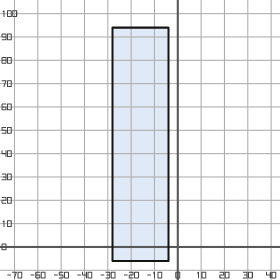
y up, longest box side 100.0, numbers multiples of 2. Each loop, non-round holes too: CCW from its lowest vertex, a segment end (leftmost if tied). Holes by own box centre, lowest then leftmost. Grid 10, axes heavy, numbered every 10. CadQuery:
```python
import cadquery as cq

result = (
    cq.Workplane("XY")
    .moveTo(-28.0, -6.0)
    .lineTo(-4.0, -6.0)
    .lineTo(-4.0, 94.0)
    .lineTo(-28.0, 94.0)
    .close()
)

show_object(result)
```